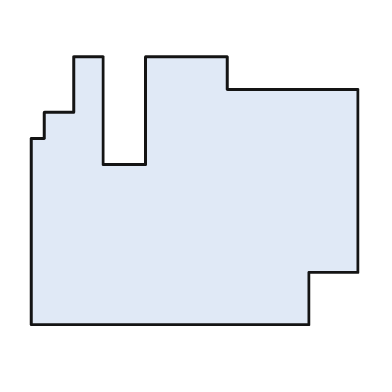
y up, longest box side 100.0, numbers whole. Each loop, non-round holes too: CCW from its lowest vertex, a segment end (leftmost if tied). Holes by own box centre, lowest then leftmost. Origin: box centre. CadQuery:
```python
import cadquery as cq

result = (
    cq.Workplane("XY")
    .moveTo(-50.0, -41.0)
    .lineTo(35.0, -41.0)
    .lineTo(35.0, -25.0)
    .lineTo(50.0, -25.0)
    .lineTo(50.0, 31.0)
    .lineTo(10.0, 31.0)
    .lineTo(10.0, 41.0)
    .lineTo(-15.0, 41.0)
    .lineTo(-15.0, 8.0)
    .lineTo(-28.0, 8.0)
    .lineTo(-28.0, 41.0)
    .lineTo(-37.0, 41.0)
    .lineTo(-37.0, 24.0)
    .lineTo(-46.0, 24.0)
    .lineTo(-46.0, 16.0)
    .lineTo(-50.0, 16.0)
    .close()
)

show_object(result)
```